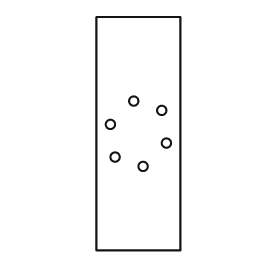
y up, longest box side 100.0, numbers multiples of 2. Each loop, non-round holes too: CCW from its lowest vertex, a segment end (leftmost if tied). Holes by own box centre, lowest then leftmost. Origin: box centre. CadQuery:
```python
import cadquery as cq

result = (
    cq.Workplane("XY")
    .moveTo(-18.0, -50.0)
    .lineTo(18.0, -50.0)
    .lineTo(18.0, 50.0)
    .lineTo(-18.0, 50.0)
    .close()
    .moveTo(2.0, -14.0)
    .circle(2.0)
    .moveTo(-10.0, -10.0)
    .circle(2.0)
    .moveTo(12.0, -4.0)
    .circle(2.0)
    .moveTo(-12.0, 4.0)
    .circle(2.0)
    .moveTo(10.0, 10.0)
    .circle(2.0)
    .moveTo(-2.0, 14.0)
    .circle(2.0)
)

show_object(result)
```